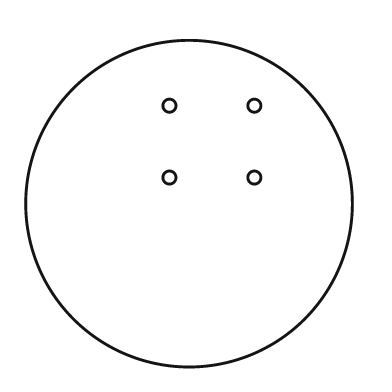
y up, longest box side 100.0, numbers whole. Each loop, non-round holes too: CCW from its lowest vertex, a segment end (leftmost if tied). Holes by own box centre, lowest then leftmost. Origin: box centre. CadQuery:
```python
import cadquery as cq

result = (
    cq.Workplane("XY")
    .moveTo(0.0, 0.0)
    .circle(50.0)
    .moveTo(-6.0, 8.0)
    .circle(2.0)
    .moveTo(20.0, 8.0)
    .circle(2.0)
    .moveTo(-6.0, 30.0)
    .circle(2.0)
    .moveTo(20.0, 30.0)
    .circle(2.0)
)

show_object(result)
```